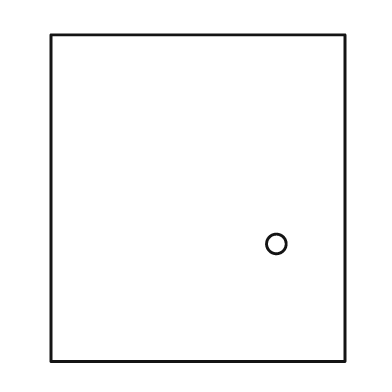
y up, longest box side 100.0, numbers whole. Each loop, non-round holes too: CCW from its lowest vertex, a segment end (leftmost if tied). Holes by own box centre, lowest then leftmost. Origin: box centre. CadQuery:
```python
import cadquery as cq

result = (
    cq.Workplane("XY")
    .moveTo(-45.0, -50.0)
    .lineTo(45.0, -50.0)
    .lineTo(45.0, 50.0)
    .lineTo(-45.0, 50.0)
    .close()
    .moveTo(24.0, -14.0)
    .circle(3.0)
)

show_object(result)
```